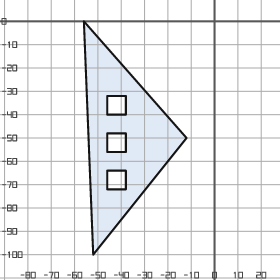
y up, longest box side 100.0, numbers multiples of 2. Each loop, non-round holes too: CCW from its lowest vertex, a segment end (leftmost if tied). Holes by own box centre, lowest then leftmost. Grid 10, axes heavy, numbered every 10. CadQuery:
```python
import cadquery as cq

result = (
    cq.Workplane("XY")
    .moveTo(-52.0, -100.0)
    .lineTo(-12.0, -50.0)
    .lineTo(-56.0, 0.0)
    .close()
    .moveTo(-46.0, -72.0)
    .lineTo(-38.0, -72.0)
    .lineTo(-38.0, -64.0)
    .lineTo(-46.0, -64.0)
    .close()
    .moveTo(-46.0, -56.0)
    .lineTo(-38.0, -56.0)
    .lineTo(-38.0, -48.0)
    .lineTo(-46.0, -48.0)
    .close()
    .moveTo(-46.0, -40.0)
    .lineTo(-38.0, -40.0)
    .lineTo(-38.0, -32.0)
    .lineTo(-46.0, -32.0)
    .close()
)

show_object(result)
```